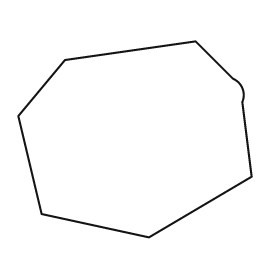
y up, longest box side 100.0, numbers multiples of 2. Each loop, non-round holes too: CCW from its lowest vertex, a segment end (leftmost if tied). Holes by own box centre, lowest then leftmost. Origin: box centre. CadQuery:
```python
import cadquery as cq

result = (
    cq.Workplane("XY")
    .moveTo(6.0, -42.0)
    .lineTo(50.0, -16.0)
    .lineTo(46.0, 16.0)
    .threePointArc((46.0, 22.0), (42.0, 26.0))
    .lineTo(26.0, 42.0)
    .lineTo(-30.0, 34.0)
    .lineTo(-50.0, 10.0)
    .lineTo(-40.0, -32.0)
    .close()
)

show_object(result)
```